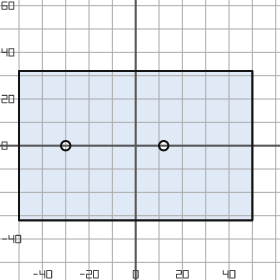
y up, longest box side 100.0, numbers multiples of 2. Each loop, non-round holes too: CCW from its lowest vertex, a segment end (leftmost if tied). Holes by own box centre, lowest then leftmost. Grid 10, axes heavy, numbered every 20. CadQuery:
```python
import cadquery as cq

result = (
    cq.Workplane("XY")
    .moveTo(-50.0, -32.0)
    .lineTo(50.0, -32.0)
    .lineTo(50.0, 32.0)
    .lineTo(-50.0, 32.0)
    .close()
    .moveTo(-30.0, 0.0)
    .circle(2.0)
    .moveTo(12.0, 0.0)
    .circle(2.0)
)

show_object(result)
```